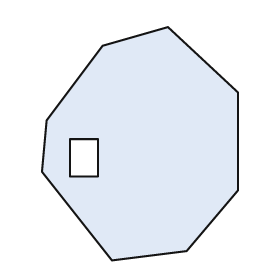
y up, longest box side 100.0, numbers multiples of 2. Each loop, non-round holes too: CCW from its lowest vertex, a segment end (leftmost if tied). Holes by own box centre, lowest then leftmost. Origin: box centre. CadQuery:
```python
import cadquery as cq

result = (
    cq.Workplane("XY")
    .moveTo(-12.0, -50.0)
    .lineTo(20.0, -46.0)
    .lineTo(42.0, -20.0)
    .lineTo(42.0, 22.0)
    .lineTo(12.0, 50.0)
    .lineTo(-16.0, 42.0)
    .lineTo(-40.0, 10.0)
    .lineTo(-42.0, -12.0)
    .close()
    .moveTo(-30.0, -14.0)
    .lineTo(-18.0, -14.0)
    .lineTo(-18.0, 2.0)
    .lineTo(-30.0, 2.0)
    .close()
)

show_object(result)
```